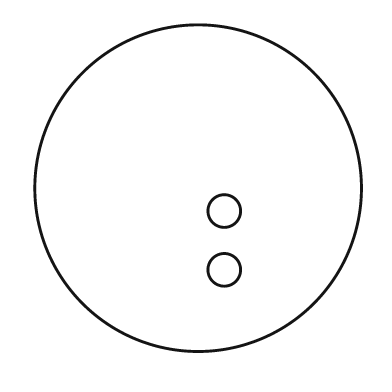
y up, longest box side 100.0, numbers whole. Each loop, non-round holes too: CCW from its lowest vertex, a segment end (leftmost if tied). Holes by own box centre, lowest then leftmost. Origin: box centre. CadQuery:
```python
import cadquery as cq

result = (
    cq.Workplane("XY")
    .moveTo(0.0, 0.0)
    .circle(50.0)
    .moveTo(8.0, -25.0)
    .circle(5.0)
    .moveTo(8.0, -7.0)
    .circle(5.0)
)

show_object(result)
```